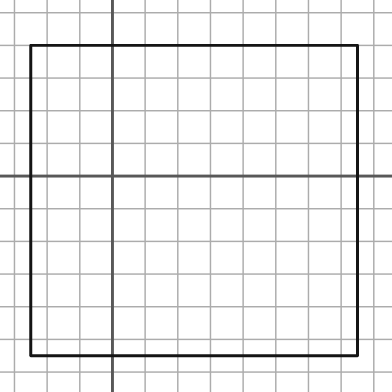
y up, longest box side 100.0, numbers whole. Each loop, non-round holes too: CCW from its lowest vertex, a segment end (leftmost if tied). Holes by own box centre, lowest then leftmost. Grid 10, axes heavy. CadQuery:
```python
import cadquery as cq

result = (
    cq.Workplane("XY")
    .moveTo(-25.0, -55.0)
    .lineTo(75.0, -55.0)
    .lineTo(75.0, 40.0)
    .lineTo(-25.0, 40.0)
    .close()
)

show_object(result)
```